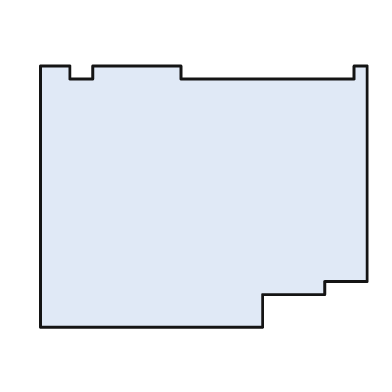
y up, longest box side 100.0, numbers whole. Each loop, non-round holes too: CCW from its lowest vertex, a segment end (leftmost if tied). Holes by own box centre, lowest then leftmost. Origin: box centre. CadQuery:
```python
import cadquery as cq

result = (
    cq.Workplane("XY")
    .moveTo(-50.0, -40.0)
    .lineTo(18.0, -40.0)
    .lineTo(18.0, -30.0)
    .lineTo(37.0, -30.0)
    .lineTo(37.0, -26.0)
    .lineTo(50.0, -26.0)
    .lineTo(50.0, 40.0)
    .lineTo(46.0, 40.0)
    .lineTo(46.0, 36.0)
    .lineTo(-7.0, 36.0)
    .lineTo(-7.0, 40.0)
    .lineTo(-34.0, 40.0)
    .lineTo(-34.0, 36.0)
    .lineTo(-41.0, 36.0)
    .lineTo(-41.0, 40.0)
    .lineTo(-50.0, 40.0)
    .close()
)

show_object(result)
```